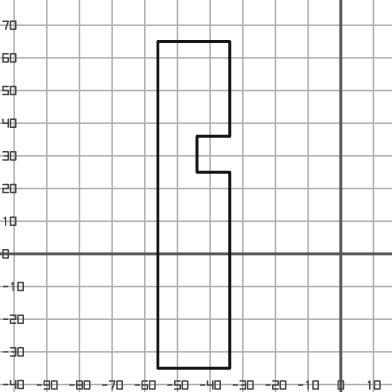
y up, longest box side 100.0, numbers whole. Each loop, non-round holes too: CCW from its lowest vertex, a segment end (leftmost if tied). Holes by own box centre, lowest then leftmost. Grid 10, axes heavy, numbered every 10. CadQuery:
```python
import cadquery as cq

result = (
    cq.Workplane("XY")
    .moveTo(-56.0, -35.0)
    .lineTo(-34.0, -35.0)
    .lineTo(-34.0, 25.0)
    .lineTo(-44.0, 25.0)
    .lineTo(-44.0, 36.0)
    .lineTo(-34.0, 36.0)
    .lineTo(-34.0, 65.0)
    .lineTo(-56.0, 65.0)
    .close()
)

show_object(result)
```